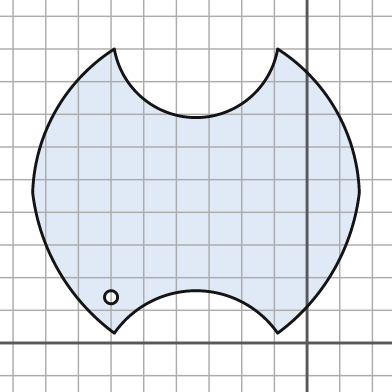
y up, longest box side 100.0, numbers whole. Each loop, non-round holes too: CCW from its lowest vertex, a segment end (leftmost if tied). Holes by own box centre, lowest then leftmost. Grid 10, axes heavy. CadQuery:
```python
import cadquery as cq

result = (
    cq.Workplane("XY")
    .moveTo(-59.0, 3.0)
    .threePointArc((-34.0, 16.0), (-9.0, 3.0))
    .threePointArc((8.0, 22.0), (16.0, 46.0))
    .threePointArc((9.0, 71.0), (-9.0, 90.0))
    .threePointArc((-34.0, 69.0), (-59.0, 90.0))
    .threePointArc((-77.0, 71.0), (-84.0, 46.0))
    .threePointArc((-76.0, 22.0), (-59.0, 3.0))
    .close()
    .moveTo(-60.0, 14.0)
    .circle(2.0)
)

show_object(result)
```